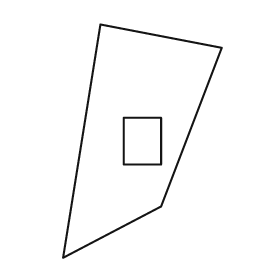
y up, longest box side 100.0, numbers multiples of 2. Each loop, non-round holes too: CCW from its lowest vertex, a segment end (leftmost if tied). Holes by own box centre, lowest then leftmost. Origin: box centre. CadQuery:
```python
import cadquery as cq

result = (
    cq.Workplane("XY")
    .moveTo(-34.0, -50.0)
    .lineTo(8.0, -28.0)
    .lineTo(34.0, 40.0)
    .lineTo(-18.0, 50.0)
    .close()
    .moveTo(-8.0, -10.0)
    .lineTo(8.0, -10.0)
    .lineTo(8.0, 10.0)
    .lineTo(-8.0, 10.0)
    .close()
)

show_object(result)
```